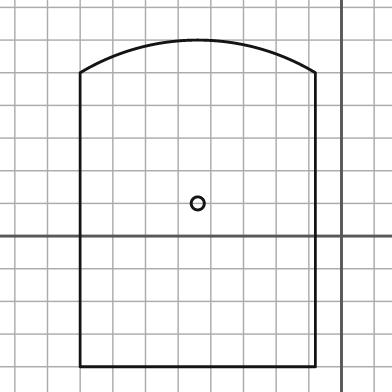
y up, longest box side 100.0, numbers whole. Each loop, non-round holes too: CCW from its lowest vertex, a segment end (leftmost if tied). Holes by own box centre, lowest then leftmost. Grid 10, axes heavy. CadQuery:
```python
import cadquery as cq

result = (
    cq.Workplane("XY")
    .moveTo(-80.0, -40.0)
    .lineTo(-8.0, -40.0)
    .lineTo(-8.0, 50.0)
    .threePointArc((-44.0, 60.0), (-80.0, 50.0))
    .close()
    .moveTo(-44.0, 10.0)
    .circle(2.0)
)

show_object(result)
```